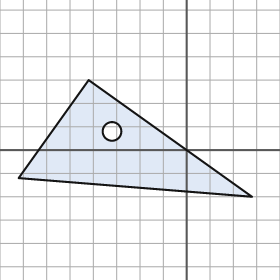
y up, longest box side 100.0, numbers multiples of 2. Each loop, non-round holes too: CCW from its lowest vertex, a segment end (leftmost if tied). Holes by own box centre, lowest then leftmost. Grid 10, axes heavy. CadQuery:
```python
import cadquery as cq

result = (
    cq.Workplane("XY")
    .moveTo(28.0, -20.0)
    .lineTo(-42.0, 30.0)
    .lineTo(-72.0, -12.0)
    .close()
    .moveTo(-32.0, 8.0)
    .circle(4.0)
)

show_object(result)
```